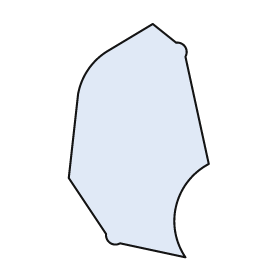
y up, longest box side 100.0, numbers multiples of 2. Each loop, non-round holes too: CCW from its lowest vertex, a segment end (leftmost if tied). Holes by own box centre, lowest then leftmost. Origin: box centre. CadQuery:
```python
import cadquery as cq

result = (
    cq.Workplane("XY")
    .moveTo(20.0, -50.0)
    .threePointArc((16.0, -28.0), (30.0, -10.0))
    .lineTo(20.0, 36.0)
    .threePointArc((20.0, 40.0), (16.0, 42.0))
    .lineTo(6.0, 50.0)
    .lineTo(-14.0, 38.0)
    .threePointArc((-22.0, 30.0), (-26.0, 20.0))
    .lineTo(-30.0, -16.0)
    .lineTo(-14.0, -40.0)
    .threePointArc((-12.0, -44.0), (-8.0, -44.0))
    .close()
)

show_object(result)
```